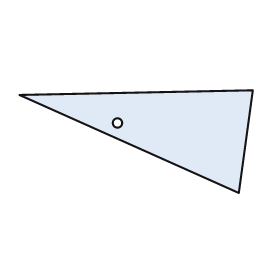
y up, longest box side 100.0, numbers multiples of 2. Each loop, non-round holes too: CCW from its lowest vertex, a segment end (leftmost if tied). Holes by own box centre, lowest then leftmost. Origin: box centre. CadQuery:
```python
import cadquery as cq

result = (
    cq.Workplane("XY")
    .moveTo(44.0, -22.0)
    .lineTo(50.0, 22.0)
    .lineTo(-50.0, 20.0)
    .close()
    .moveTo(-8.0, 8.0)
    .circle(2.0)
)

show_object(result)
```